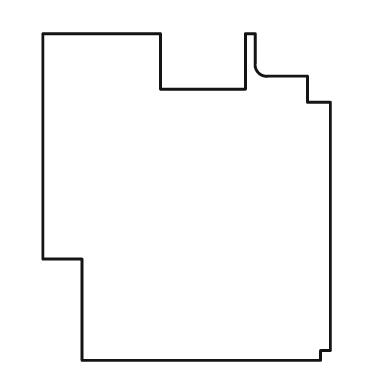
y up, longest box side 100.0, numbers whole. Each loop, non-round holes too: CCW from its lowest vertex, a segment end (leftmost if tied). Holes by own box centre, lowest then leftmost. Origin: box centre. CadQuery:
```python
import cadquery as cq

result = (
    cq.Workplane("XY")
    .moveTo(-32.0, -50.0)
    .lineTo(41.0, -50.0)
    .lineTo(41.0, -47.0)
    .lineTo(44.0, -47.0)
    .lineTo(44.0, 29.0)
    .lineTo(37.0, 29.0)
    .lineTo(37.0, 37.0)
    .lineTo(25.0, 37.0)
    .threePointArc((22.0, 38.0), (21.0, 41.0))
    .lineTo(21.0, 50.0)
    .lineTo(18.0, 50.0)
    .lineTo(18.0, 33.0)
    .lineTo(-8.0, 33.0)
    .lineTo(-8.0, 50.0)
    .lineTo(-44.0, 50.0)
    .lineTo(-44.0, -19.0)
    .lineTo(-32.0, -19.0)
    .close()
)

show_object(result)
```